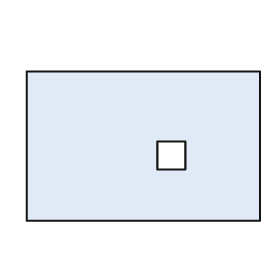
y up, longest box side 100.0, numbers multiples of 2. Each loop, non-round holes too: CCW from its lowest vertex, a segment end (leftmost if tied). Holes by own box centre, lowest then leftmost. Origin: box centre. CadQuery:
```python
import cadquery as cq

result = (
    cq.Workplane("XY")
    .moveTo(-50.0, -32.0)
    .lineTo(50.0, -32.0)
    .lineTo(50.0, 32.0)
    .lineTo(-50.0, 32.0)
    .close()
    .moveTo(6.0, -10.0)
    .lineTo(18.0, -10.0)
    .lineTo(18.0, 2.0)
    .lineTo(6.0, 2.0)
    .close()
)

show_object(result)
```